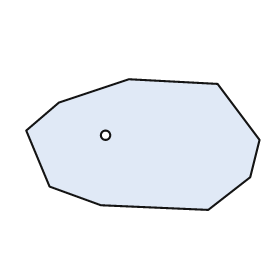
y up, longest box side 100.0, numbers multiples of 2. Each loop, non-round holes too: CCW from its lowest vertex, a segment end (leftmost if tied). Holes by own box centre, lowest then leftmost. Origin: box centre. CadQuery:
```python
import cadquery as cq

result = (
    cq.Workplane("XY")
    .moveTo(28.0, -28.0)
    .lineTo(46.0, -14.0)
    .lineTo(50.0, 2.0)
    .lineTo(32.0, 26.0)
    .lineTo(-6.0, 28.0)
    .lineTo(-36.0, 18.0)
    .lineTo(-50.0, 6.0)
    .lineTo(-40.0, -18.0)
    .lineTo(-18.0, -26.0)
    .close()
    .moveTo(-16.0, 4.0)
    .circle(2.0)
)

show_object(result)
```